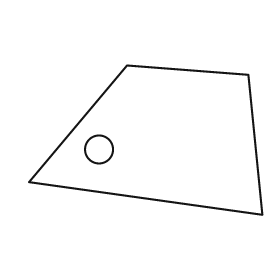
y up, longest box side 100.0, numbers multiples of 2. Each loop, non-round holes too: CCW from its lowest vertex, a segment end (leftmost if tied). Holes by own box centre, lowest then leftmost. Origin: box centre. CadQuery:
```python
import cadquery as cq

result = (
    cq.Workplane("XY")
    .moveTo(50.0, -32.0)
    .lineTo(44.0, 28.0)
    .lineTo(-8.0, 32.0)
    .lineTo(-50.0, -18.0)
    .close()
    .moveTo(-20.0, -4.0)
    .circle(6.0)
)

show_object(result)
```